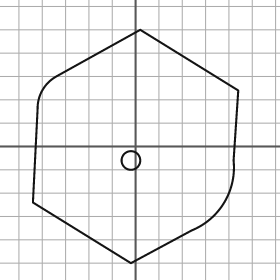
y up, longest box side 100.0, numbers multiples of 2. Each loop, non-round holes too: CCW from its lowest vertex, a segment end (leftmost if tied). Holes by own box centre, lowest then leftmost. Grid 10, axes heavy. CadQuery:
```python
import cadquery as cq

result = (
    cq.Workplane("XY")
    .moveTo(-2.0, -50.0)
    .lineTo(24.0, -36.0)
    .threePointArc((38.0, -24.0), (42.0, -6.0))
    .lineTo(44.0, 24.0)
    .lineTo(2.0, 50.0)
    .lineTo(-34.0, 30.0)
    .threePointArc((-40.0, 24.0), (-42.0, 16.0))
    .lineTo(-44.0, -24.0)
    .close()
    .moveTo(-2.0, -6.0)
    .circle(4.0)
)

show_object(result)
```